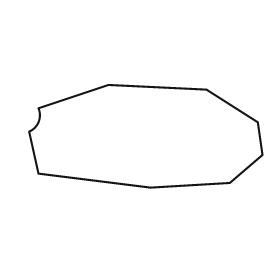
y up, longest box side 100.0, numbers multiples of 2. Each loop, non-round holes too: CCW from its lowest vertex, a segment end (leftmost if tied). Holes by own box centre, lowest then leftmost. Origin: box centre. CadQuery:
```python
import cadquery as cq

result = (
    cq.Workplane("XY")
    .moveTo(2.0, -22.0)
    .lineTo(36.0, -20.0)
    .lineTo(50.0, -8.0)
    .lineTo(48.0, 6.0)
    .lineTo(26.0, 20.0)
    .lineTo(-16.0, 22.0)
    .lineTo(-46.0, 12.0)
    .threePointArc((-46.0, 6.0), (-50.0, 2.0))
    .lineTo(-46.0, -16.0)
    .close()
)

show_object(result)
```